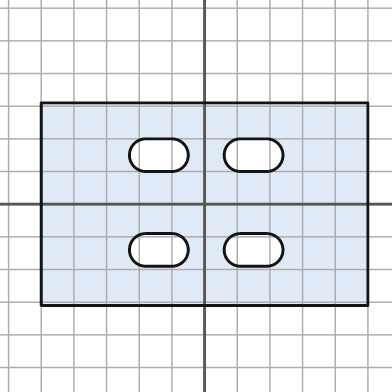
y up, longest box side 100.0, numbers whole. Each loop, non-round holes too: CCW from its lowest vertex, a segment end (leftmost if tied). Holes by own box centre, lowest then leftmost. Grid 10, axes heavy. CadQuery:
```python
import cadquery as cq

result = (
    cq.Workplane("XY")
    .moveTo(-50.0, -31.0)
    .lineTo(50.0, -31.0)
    .lineTo(50.0, 31.0)
    .lineTo(-50.0, 31.0)
    .close()
    .moveTo(-18.0, -19.0)
    .lineTo(-10.0, -19.0)
    .threePointArc((-5.0, -14.0), (-10.0, -9.0))
    .lineTo(-18.0, -9.0)
    .threePointArc((-23.0, -14.0), (-18.0, -19.0))
    .close()
    .moveTo(11.0, -19.0)
    .lineTo(19.0, -19.0)
    .threePointArc((24.0, -14.0), (19.0, -9.0))
    .lineTo(11.0, -9.0)
    .threePointArc((6.0, -14.0), (11.0, -19.0))
    .close()
    .moveTo(-18.0, 10.0)
    .lineTo(-10.0, 10.0)
    .threePointArc((-5.0, 15.0), (-10.0, 20.0))
    .lineTo(-18.0, 20.0)
    .threePointArc((-23.0, 15.0), (-18.0, 10.0))
    .close()
    .moveTo(11.0, 10.0)
    .lineTo(19.0, 10.0)
    .threePointArc((24.0, 15.0), (19.0, 20.0))
    .lineTo(11.0, 20.0)
    .threePointArc((6.0, 15.0), (11.0, 10.0))
    .close()
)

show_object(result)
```